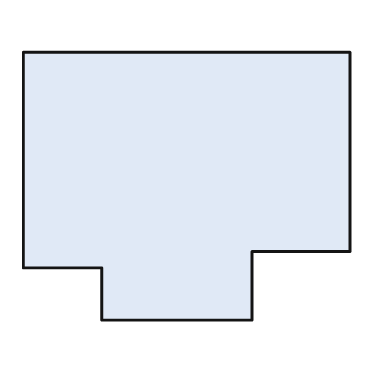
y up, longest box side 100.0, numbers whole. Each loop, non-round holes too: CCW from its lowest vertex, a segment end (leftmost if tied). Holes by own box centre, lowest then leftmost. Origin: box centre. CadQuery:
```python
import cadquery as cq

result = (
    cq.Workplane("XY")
    .moveTo(-26.0, -41.0)
    .lineTo(20.0, -41.0)
    .lineTo(20.0, -20.0)
    .lineTo(50.0, -20.0)
    .lineTo(50.0, 41.0)
    .lineTo(-50.0, 41.0)
    .lineTo(-50.0, -25.0)
    .lineTo(-26.0, -25.0)
    .close()
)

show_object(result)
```